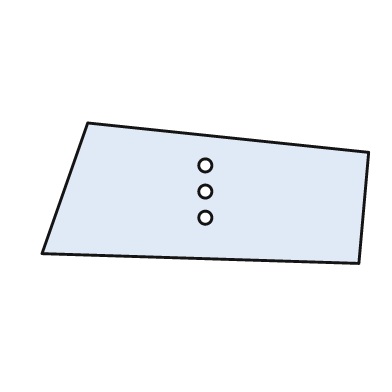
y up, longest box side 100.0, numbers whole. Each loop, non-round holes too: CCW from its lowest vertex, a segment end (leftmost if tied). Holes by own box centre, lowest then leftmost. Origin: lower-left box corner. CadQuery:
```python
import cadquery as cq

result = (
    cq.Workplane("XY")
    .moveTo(97.0, 0.0)
    .lineTo(100.0, 34.0)
    .lineTo(14.0, 43.0)
    .lineTo(0.0, 3.0)
    .close()
    .moveTo(50.0, 14.0)
    .circle(2.0)
    .moveTo(50.0, 22.0)
    .circle(2.0)
    .moveTo(50.0, 30.0)
    .circle(2.0)
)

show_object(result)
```